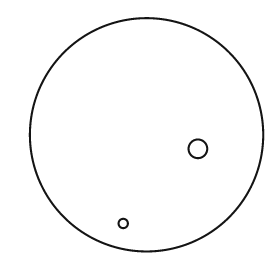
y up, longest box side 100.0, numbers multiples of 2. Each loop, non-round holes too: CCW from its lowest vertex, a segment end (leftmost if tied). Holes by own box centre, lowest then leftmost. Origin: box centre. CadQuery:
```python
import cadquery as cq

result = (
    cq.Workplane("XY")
    .moveTo(0.0, 0.0)
    .circle(50.0)
    .moveTo(-10.0, -38.0)
    .circle(2.0)
    .moveTo(22.0, -6.0)
    .circle(4.0)
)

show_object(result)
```